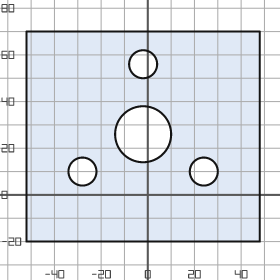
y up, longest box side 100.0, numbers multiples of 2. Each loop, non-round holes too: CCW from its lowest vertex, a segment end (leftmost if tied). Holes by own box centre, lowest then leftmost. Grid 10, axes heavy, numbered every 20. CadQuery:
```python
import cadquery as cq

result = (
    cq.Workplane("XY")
    .moveTo(-52.0, -20.0)
    .lineTo(48.0, -20.0)
    .lineTo(48.0, 70.0)
    .lineTo(-52.0, 70.0)
    .close()
    .moveTo(-28.0, 10.0)
    .circle(6.0)
    .moveTo(24.0, 10.0)
    .circle(6.0)
    .moveTo(-2.0, 26.0)
    .circle(12.0)
    .moveTo(-2.0, 56.0)
    .circle(6.0)
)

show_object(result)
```